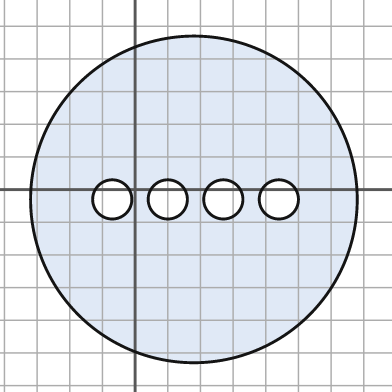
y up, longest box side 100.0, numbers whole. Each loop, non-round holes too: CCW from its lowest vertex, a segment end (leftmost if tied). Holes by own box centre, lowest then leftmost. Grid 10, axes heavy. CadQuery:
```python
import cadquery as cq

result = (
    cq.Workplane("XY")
    .moveTo(18.0, -3.0)
    .circle(50.0)
    .moveTo(-7.0, -3.0)
    .circle(6.0)
    .moveTo(10.0, -3.0)
    .circle(6.0)
    .moveTo(27.0, -3.0)
    .circle(6.0)
    .moveTo(44.0, -3.0)
    .circle(6.0)
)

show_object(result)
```